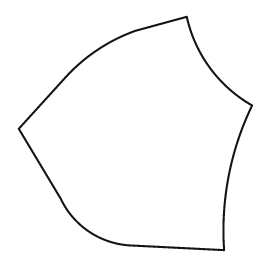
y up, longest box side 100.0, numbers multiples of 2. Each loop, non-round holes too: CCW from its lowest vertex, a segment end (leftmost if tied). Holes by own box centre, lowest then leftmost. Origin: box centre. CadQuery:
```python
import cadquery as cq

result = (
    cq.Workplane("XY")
    .moveTo(38.0, -50.0)
    .threePointArc((40.0, -18.0), (50.0, 12.0))
    .threePointArc((32.0, 28.0), (22.0, 50.0))
    .lineTo(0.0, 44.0)
    .threePointArc((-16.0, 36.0), (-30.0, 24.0))
    .lineTo(-50.0, 2.0)
    .lineTo(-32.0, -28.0)
    .threePointArc((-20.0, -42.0), (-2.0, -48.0))
    .close()
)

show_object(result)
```